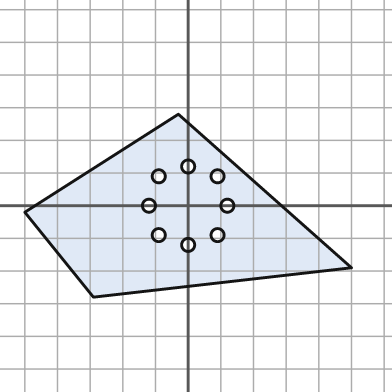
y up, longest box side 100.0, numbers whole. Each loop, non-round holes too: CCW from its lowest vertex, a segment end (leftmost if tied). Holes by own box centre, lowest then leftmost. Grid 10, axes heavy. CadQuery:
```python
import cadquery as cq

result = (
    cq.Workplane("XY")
    .moveTo(-29.0, -28.0)
    .lineTo(50.0, -19.0)
    .lineTo(-3.0, 28.0)
    .lineTo(-50.0, -2.0)
    .close()
    .moveTo(0.0, -12.0)
    .circle(2.0)
    .moveTo(-9.0, -9.0)
    .circle(2.0)
    .moveTo(9.0, -9.0)
    .circle(2.0)
    .moveTo(-12.0, 0.0)
    .circle(2.0)
    .moveTo(12.0, 0.0)
    .circle(2.0)
    .moveTo(-9.0, 9.0)
    .circle(2.0)
    .moveTo(9.0, 9.0)
    .circle(2.0)
    .moveTo(0.0, 12.0)
    .circle(2.0)
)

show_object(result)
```